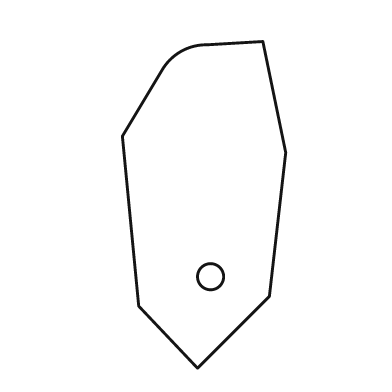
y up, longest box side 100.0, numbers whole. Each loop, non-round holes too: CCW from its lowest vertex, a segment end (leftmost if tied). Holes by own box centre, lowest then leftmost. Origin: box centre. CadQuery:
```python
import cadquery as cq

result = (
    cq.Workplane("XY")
    .moveTo(-2.0, -50.0)
    .lineTo(20.0, -28.0)
    .lineTo(25.0, 16.0)
    .lineTo(18.0, 50.0)
    .lineTo(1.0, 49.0)
    .threePointArc((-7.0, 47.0), (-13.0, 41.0))
    .lineTo(-25.0, 21.0)
    .lineTo(-20.0, -31.0)
    .close()
    .moveTo(2.0, -22.0)
    .circle(4.0)
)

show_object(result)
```